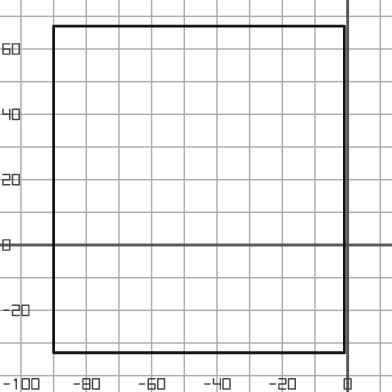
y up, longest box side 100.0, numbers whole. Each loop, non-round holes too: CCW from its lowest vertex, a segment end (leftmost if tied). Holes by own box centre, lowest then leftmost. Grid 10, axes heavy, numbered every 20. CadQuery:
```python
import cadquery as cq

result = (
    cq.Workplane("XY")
    .moveTo(-90.0, -33.0)
    .lineTo(-1.0, -33.0)
    .lineTo(-1.0, 67.0)
    .lineTo(-90.0, 67.0)
    .close()
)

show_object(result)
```